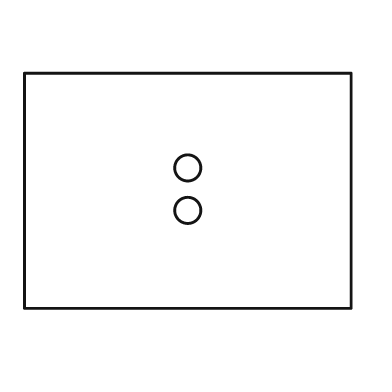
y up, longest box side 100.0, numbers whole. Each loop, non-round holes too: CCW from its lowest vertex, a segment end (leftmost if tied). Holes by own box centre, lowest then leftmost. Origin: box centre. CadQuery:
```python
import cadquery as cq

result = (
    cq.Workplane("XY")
    .moveTo(-50.0, -36.0)
    .lineTo(50.0, -36.0)
    .lineTo(50.0, 36.0)
    .lineTo(-50.0, 36.0)
    .close()
    .moveTo(0.0, -6.0)
    .circle(4.0)
    .moveTo(0.0, 7.0)
    .circle(4.0)
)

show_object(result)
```